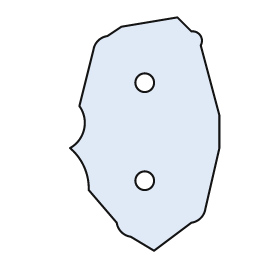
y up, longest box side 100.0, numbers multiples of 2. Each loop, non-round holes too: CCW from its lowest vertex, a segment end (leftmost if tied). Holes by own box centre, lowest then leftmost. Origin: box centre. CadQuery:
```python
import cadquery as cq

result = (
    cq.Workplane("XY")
    .moveTo(4.0, -50.0)
    .lineTo(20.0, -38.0)
    .threePointArc((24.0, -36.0), (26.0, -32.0))
    .lineTo(32.0, -6.0)
    .lineTo(32.0, 8.0)
    .lineTo(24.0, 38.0)
    .threePointArc((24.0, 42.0), (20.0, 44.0))
    .lineTo(14.0, 50.0)
    .lineTo(-10.0, 46.0)
    .lineTo(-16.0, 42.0)
    .threePointArc((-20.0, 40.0), (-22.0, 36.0))
    .lineTo(-28.0, 12.0)
    .threePointArc((-26.0, 2.0), (-32.0, -6.0))
    .threePointArc((-26.0, -14.0), (-24.0, -24.0))
    .lineTo(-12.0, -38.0)
    .threePointArc((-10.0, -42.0), (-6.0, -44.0))
    .close()
    .moveTo(0.0, -20.0)
    .circle(4.0)
    .moveTo(0.0, 22.0)
    .circle(4.0)
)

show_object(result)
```